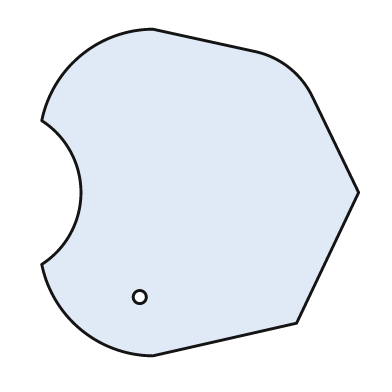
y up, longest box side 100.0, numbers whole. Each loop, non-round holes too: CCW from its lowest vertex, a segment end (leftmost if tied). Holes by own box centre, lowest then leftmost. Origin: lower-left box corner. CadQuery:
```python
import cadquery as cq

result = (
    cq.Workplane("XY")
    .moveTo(34.0, 0.0)
    .lineTo(78.0, 10.0)
    .lineTo(97.0, 50.0)
    .lineTo(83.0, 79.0)
    .threePointArc((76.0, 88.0), (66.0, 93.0))
    .lineTo(34.0, 100.0)
    .threePointArc((12.0, 92.0), (0.0, 72.0))
    .threePointArc((12.0, 50.0), (0.0, 28.0))
    .threePointArc((12.0, 8.0), (34.0, 0.0))
    .close()
    .moveTo(30.0, 18.0)
    .circle(2.0)
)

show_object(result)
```